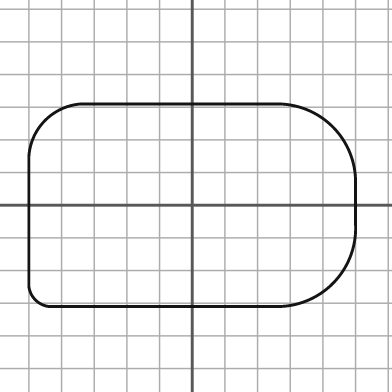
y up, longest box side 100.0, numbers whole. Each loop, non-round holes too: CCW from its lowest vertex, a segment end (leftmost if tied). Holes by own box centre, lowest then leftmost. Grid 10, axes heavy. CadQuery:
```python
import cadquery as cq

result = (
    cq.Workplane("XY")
    .moveTo(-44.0, -31.0)
    .lineTo(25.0, -31.0)
    .threePointArc((43.0, -24.0), (50.0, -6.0))
    .lineTo(50.0, 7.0)
    .threePointArc((43.0, 24.0), (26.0, 31.0))
    .lineTo(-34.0, 31.0)
    .threePointArc((-45.0, 26.0), (-50.0, 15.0))
    .lineTo(-50.0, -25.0)
    .threePointArc((-48.0, -29.0), (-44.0, -31.0))
    .close()
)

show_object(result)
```